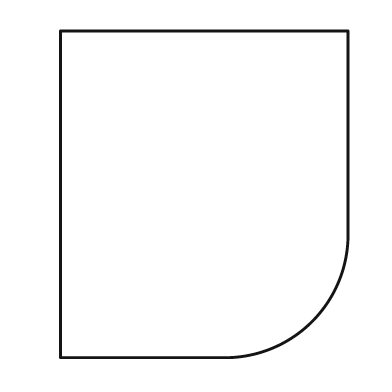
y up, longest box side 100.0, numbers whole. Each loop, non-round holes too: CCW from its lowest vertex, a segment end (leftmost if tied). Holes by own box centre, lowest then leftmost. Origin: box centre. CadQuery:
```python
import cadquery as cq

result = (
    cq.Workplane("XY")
    .moveTo(-44.0, -50.0)
    .lineTo(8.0, -50.0)
    .threePointArc((33.0, -39.0), (44.0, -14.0))
    .lineTo(44.0, 50.0)
    .lineTo(-44.0, 50.0)
    .close()
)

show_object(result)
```